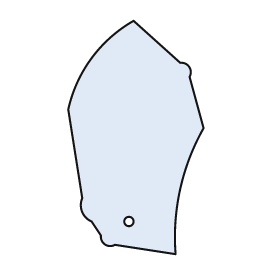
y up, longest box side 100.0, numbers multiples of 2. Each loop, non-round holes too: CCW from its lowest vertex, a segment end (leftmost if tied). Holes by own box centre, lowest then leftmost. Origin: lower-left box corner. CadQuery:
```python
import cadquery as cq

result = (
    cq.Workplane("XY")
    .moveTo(46.0, 0.0)
    .threePointArc((48.0, 28.0), (58.0, 54.0))
    .lineTo(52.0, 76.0)
    .threePointArc((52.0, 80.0), (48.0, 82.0))
    .lineTo(28.0, 100.0)
    .threePointArc((10.0, 84.0), (0.0, 62.0))
    .lineTo(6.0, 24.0)
    .threePointArc((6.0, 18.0), (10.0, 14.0))
    .lineTo(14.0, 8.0)
    .threePointArc((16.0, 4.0), (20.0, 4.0))
    .close()
    .moveTo(26.0, 14.0)
    .circle(2.0)
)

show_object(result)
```